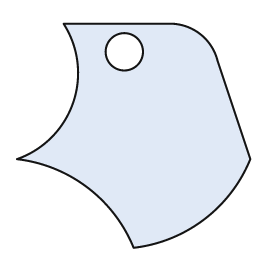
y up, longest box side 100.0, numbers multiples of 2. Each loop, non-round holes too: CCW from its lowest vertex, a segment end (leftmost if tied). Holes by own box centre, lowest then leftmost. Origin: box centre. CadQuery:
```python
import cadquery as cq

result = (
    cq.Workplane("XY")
    .moveTo(0.0, -48.0)
    .threePointArc((30.0, -36.0), (50.0, -10.0))
    .lineTo(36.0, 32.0)
    .threePointArc((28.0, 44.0), (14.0, 48.0))
    .lineTo(-30.0, 48.0)
    .threePointArc((-26.0, 14.0), (-50.0, -10.0))
    .threePointArc((-20.0, -22.0), (0.0, -48.0))
    .close()
    .moveTo(-4.0, 36.0)
    .circle(8.0)
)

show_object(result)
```